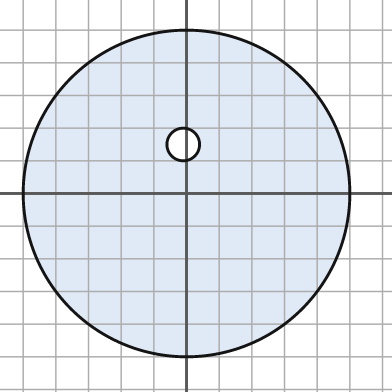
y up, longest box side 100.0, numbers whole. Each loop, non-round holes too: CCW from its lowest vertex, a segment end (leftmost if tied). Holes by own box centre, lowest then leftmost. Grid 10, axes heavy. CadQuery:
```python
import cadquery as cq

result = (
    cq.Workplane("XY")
    .moveTo(0.0, 0.0)
    .circle(50.0)
    .moveTo(-1.0, 15.0)
    .circle(5.0)
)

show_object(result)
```